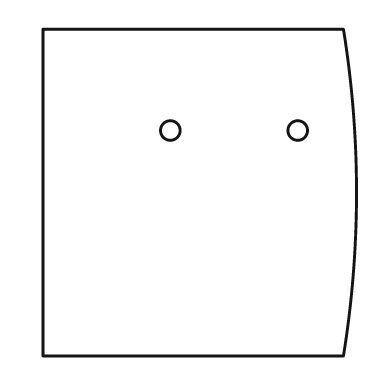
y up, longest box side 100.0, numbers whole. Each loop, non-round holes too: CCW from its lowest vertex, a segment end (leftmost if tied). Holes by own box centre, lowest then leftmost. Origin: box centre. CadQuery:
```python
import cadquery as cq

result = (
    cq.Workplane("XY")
    .moveTo(-48.0, -50.0)
    .lineTo(44.0, -50.0)
    .threePointArc((48.0, 0.0), (44.0, 50.0))
    .lineTo(-48.0, 50.0)
    .close()
    .moveTo(-9.0, 19.0)
    .circle(3.0)
    .moveTo(30.0, 19.0)
    .circle(3.0)
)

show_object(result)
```